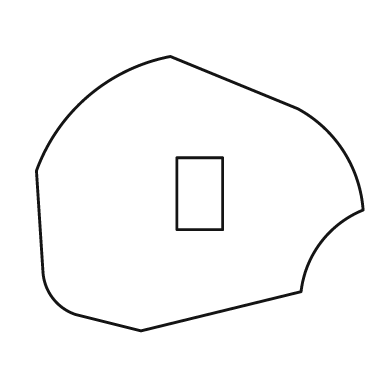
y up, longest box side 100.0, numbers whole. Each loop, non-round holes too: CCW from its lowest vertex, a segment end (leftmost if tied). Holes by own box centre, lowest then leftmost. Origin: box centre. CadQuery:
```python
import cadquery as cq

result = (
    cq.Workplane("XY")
    .moveTo(-18.0, -42.0)
    .lineTo(31.0, -30.0)
    .threePointArc((37.0, -15.0), (50.0, -5.0))
    .threePointArc((44.0, 13.0), (30.0, 26.0))
    .lineTo(-9.0, 42.0)
    .threePointArc((-34.0, 30.0), (-50.0, 7.0))
    .lineTo(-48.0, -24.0)
    .threePointArc((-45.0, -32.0), (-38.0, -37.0))
    .close()
    .moveTo(-7.0, -11.0)
    .lineTo(7.0, -11.0)
    .lineTo(7.0, 11.0)
    .lineTo(-7.0, 11.0)
    .close()
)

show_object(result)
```